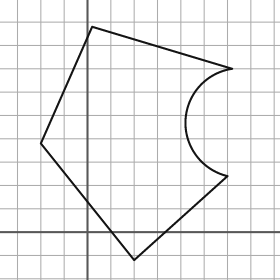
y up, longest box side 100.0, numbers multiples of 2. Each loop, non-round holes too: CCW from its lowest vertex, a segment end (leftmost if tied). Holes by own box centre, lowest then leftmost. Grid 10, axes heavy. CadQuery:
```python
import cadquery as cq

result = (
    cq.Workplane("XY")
    .moveTo(20.0, -12.0)
    .lineTo(60.0, 24.0)
    .threePointArc((42.0, 48.0), (62.0, 70.0))
    .lineTo(2.0, 88.0)
    .lineTo(-20.0, 38.0)
    .close()
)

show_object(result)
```